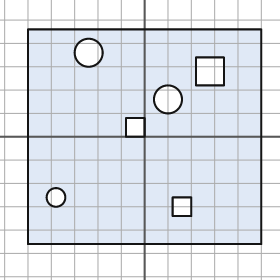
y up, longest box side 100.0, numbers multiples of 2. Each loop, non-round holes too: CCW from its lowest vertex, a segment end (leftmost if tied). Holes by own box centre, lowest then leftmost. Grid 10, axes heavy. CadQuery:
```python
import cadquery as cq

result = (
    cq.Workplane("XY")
    .moveTo(-50.0, -46.0)
    .lineTo(50.0, -46.0)
    .lineTo(50.0, 46.0)
    .lineTo(-50.0, 46.0)
    .close()
    .moveTo(12.0, -34.0)
    .lineTo(20.0, -34.0)
    .lineTo(20.0, -26.0)
    .lineTo(12.0, -26.0)
    .close()
    .moveTo(-38.0, -26.0)
    .circle(4.0)
    .moveTo(-8.0, 0.0)
    .lineTo(0.0, 0.0)
    .lineTo(0.0, 8.0)
    .lineTo(-8.0, 8.0)
    .close()
    .moveTo(10.0, 16.0)
    .circle(6.0)
    .moveTo(22.0, 22.0)
    .lineTo(34.0, 22.0)
    .lineTo(34.0, 34.0)
    .lineTo(22.0, 34.0)
    .close()
    .moveTo(-24.0, 36.0)
    .circle(6.0)
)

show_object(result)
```